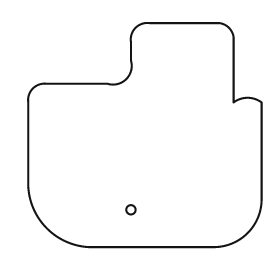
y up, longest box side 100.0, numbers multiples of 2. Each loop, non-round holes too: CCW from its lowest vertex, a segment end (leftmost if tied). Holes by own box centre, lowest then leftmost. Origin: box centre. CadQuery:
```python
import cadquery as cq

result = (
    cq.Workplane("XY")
    .moveTo(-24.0, -48.0)
    .lineTo(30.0, -48.0)
    .threePointArc((44.0, -42.0), (50.0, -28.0))
    .lineTo(50.0, 14.0)
    .threePointArc((44.0, 16.0), (38.0, 14.0))
    .lineTo(38.0, 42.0)
    .threePointArc((36.0, 46.0), (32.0, 48.0))
    .lineTo(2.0, 48.0)
    .threePointArc((-4.0, 46.0), (-6.0, 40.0))
    .lineTo(-6.0, 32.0)
    .threePointArc((-8.0, 24.0), (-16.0, 22.0))
    .lineTo(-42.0, 22.0)
    .threePointArc((-48.0, 20.0), (-50.0, 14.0))
    .lineTo(-50.0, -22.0)
    .threePointArc((-42.0, -40.0), (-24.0, -48.0))
    .close()
    .moveTo(-6.0, -32.0)
    .circle(2.0)
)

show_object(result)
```